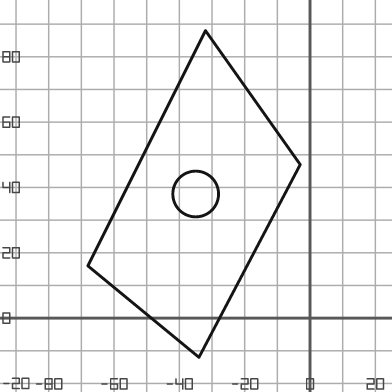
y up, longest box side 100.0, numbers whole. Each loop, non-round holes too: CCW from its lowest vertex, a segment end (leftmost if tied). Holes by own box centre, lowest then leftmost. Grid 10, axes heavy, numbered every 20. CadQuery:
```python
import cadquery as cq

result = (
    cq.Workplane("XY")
    .moveTo(-34.0, -12.0)
    .lineTo(-3.0, 47.0)
    .lineTo(-32.0, 88.0)
    .lineTo(-68.0, 16.0)
    .close()
    .moveTo(-35.0, 38.0)
    .circle(7.0)
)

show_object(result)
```